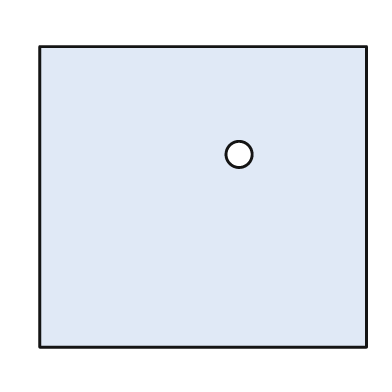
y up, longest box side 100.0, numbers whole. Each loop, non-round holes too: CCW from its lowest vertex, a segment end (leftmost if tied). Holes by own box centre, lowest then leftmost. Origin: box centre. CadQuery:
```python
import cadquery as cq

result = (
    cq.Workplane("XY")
    .moveTo(-50.0, -46.0)
    .lineTo(50.0, -46.0)
    .lineTo(50.0, 46.0)
    .lineTo(-50.0, 46.0)
    .close()
    .moveTo(11.0, 13.0)
    .circle(4.0)
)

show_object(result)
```